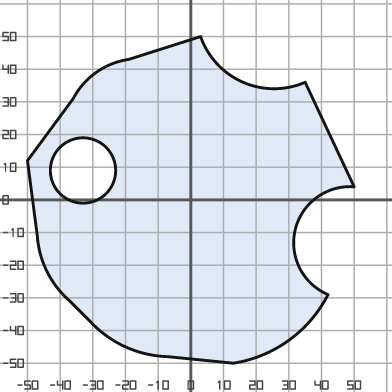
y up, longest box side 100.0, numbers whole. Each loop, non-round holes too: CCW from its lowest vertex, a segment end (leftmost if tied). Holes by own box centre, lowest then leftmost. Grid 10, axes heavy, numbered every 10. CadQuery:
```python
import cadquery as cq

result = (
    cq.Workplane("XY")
    .moveTo(13.0, -50.0)
    .threePointArc((30.0, -43.0), (42.0, -29.0))
    .threePointArc((32.0, -9.0), (50.0, 4.0))
    .lineTo(35.0, 36.0)
    .threePointArc((16.0, 36.0), (3.0, 50.0))
    .lineTo(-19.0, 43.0)
    .threePointArc((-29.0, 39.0), (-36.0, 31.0))
    .lineTo(-50.0, 12.0)
    .lineTo(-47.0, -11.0)
    .threePointArc((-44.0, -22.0), (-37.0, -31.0))
    .lineTo(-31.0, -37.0)
    .threePointArc((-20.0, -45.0), (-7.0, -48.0))
    .close()
    .moveTo(-33.0, 9.0)
    .circle(10.0)
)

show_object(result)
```